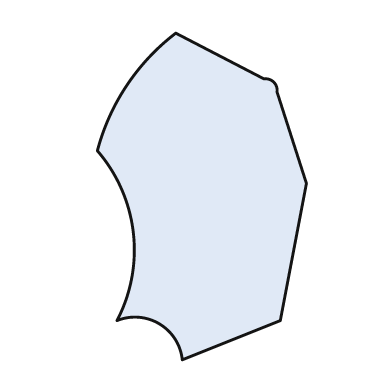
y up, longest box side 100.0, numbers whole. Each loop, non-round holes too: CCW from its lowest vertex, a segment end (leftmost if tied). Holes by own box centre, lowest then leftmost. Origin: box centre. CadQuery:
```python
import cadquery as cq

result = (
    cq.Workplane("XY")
    .moveTo(-6.0, -50.0)
    .lineTo(24.0, -38.0)
    .lineTo(32.0, 4.0)
    .lineTo(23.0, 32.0)
    .threePointArc((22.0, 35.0), (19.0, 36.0))
    .lineTo(-8.0, 50.0)
    .threePointArc((-23.0, 34.0), (-32.0, 14.0))
    .threePointArc((-21.0, -11.0), (-26.0, -38.0))
    .threePointArc((-13.0, -39.0), (-6.0, -50.0))
    .close()
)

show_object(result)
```